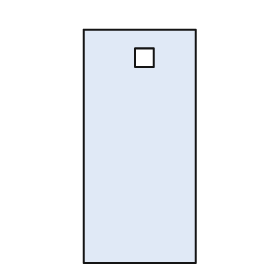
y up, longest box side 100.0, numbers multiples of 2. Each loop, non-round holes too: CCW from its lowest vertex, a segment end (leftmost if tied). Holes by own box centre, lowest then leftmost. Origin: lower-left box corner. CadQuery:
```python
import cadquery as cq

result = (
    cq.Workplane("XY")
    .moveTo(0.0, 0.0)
    .lineTo(48.0, 0.0)
    .lineTo(48.0, 100.0)
    .lineTo(0.0, 100.0)
    .close()
    .moveTo(22.0, 84.0)
    .lineTo(30.0, 84.0)
    .lineTo(30.0, 92.0)
    .lineTo(22.0, 92.0)
    .close()
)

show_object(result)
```